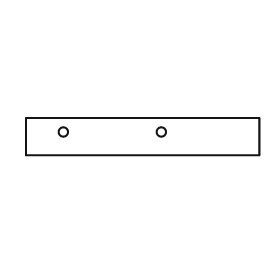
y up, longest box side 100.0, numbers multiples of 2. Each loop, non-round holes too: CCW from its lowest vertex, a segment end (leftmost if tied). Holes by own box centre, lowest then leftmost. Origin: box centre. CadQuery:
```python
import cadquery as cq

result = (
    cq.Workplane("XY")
    .moveTo(-50.0, -8.0)
    .lineTo(50.0, -8.0)
    .lineTo(50.0, 8.0)
    .lineTo(-50.0, 8.0)
    .close()
    .moveTo(-34.0, 2.0)
    .circle(2.0)
    .moveTo(8.0, 2.0)
    .circle(2.0)
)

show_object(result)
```